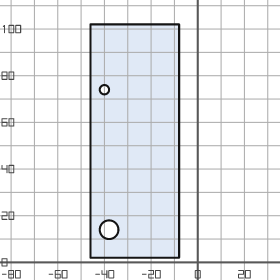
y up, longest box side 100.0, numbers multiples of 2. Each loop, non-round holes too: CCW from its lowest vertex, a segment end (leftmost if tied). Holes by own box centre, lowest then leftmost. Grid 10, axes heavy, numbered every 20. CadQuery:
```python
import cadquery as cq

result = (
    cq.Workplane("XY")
    .moveTo(-46.0, 2.0)
    .lineTo(-8.0, 2.0)
    .lineTo(-8.0, 102.0)
    .lineTo(-46.0, 102.0)
    .close()
    .moveTo(-38.0, 14.0)
    .circle(4.0)
    .moveTo(-40.0, 74.0)
    .circle(2.0)
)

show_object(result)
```